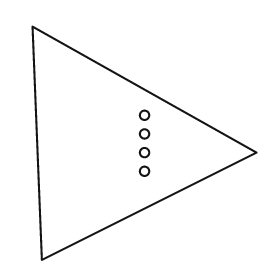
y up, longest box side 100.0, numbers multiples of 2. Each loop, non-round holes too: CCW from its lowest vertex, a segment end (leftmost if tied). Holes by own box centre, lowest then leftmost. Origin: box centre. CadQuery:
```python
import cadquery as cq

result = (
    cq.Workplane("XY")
    .moveTo(-44.0, -50.0)
    .lineTo(48.0, -4.0)
    .lineTo(-48.0, 50.0)
    .close()
    .moveTo(0.0, -12.0)
    .circle(2.0)
    .moveTo(0.0, -4.0)
    .circle(2.0)
    .moveTo(0.0, 4.0)
    .circle(2.0)
    .moveTo(0.0, 12.0)
    .circle(2.0)
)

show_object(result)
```